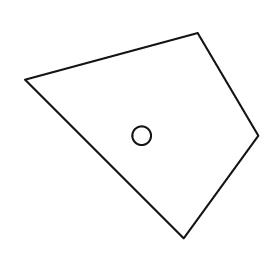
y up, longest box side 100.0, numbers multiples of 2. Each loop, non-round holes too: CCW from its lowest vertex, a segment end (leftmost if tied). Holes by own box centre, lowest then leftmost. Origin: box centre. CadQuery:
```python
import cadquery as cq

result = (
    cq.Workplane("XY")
    .moveTo(18.0, -44.0)
    .lineTo(50.0, 0.0)
    .lineTo(24.0, 44.0)
    .lineTo(-50.0, 24.0)
    .close()
    .moveTo(0.0, 0.0)
    .circle(4.0)
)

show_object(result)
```